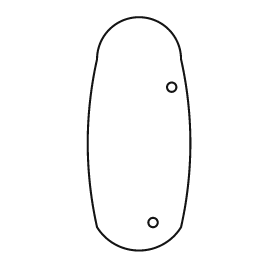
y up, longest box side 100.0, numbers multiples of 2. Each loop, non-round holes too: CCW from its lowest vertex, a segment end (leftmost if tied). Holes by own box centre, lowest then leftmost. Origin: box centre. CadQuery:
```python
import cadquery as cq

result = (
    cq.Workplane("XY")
    .moveTo(-18.0, -40.0)
    .threePointArc((0.0, -50.0), (18.0, -40.0))
    .threePointArc((22.0, -4.0), (18.0, 32.0))
    .threePointArc((0.0, 50.0), (-18.0, 32.0))
    .threePointArc((-22.0, -4.0), (-18.0, -40.0))
    .close()
    .moveTo(6.0, -38.0)
    .circle(2.0)
    .moveTo(14.0, 20.0)
    .circle(2.0)
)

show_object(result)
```